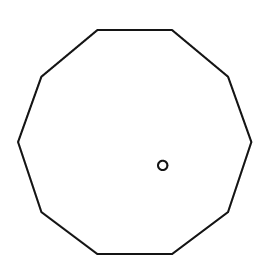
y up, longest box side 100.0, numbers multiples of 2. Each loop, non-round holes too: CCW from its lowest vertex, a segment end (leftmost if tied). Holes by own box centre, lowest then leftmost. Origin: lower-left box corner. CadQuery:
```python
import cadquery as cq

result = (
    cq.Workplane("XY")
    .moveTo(34.0, 0.0)
    .lineTo(66.0, 0.0)
    .lineTo(90.0, 18.0)
    .lineTo(100.0, 48.0)
    .lineTo(90.0, 76.0)
    .lineTo(66.0, 96.0)
    .lineTo(34.0, 96.0)
    .lineTo(10.0, 76.0)
    .lineTo(0.0, 48.0)
    .lineTo(10.0, 18.0)
    .close()
    .moveTo(62.0, 38.0)
    .circle(2.0)
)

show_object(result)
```